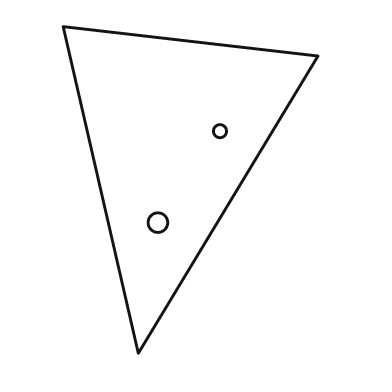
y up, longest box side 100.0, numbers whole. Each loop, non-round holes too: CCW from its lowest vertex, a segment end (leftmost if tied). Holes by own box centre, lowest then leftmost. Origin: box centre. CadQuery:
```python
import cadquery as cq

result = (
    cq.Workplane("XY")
    .moveTo(-16.0, -50.0)
    .lineTo(39.0, 41.0)
    .lineTo(-39.0, 50.0)
    .close()
    .moveTo(-10.0, -10.0)
    .circle(3.0)
    .moveTo(9.0, 18.0)
    .circle(2.0)
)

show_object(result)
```